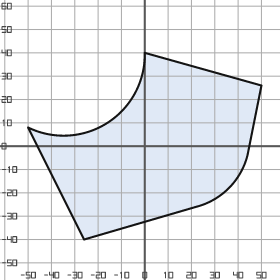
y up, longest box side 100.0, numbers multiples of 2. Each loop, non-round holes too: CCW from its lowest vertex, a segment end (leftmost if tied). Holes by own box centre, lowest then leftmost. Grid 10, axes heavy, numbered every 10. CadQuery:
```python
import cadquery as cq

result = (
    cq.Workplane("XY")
    .moveTo(-26.0, -40.0)
    .lineTo(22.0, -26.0)
    .threePointArc((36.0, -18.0), (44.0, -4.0))
    .lineTo(50.0, 26.0)
    .lineTo(0.0, 40.0)
    .threePointArc((-16.0, 10.0), (-50.0, 8.0))
    .close()
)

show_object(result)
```